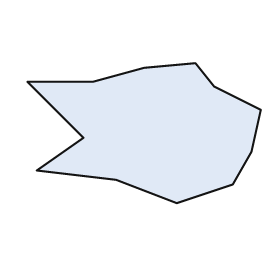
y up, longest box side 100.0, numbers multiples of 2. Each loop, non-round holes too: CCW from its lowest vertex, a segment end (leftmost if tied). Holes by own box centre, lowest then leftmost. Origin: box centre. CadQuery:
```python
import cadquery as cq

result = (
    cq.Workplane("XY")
    .moveTo(14.0, -30.0)
    .lineTo(38.0, -22.0)
    .lineTo(46.0, -8.0)
    .lineTo(50.0, 10.0)
    .lineTo(30.0, 20.0)
    .lineTo(22.0, 30.0)
    .lineTo(0.0, 28.0)
    .lineTo(-22.0, 22.0)
    .lineTo(-50.0, 22.0)
    .lineTo(-26.0, -2.0)
    .lineTo(-46.0, -16.0)
    .lineTo(-12.0, -20.0)
    .close()
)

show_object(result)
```